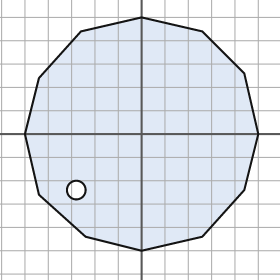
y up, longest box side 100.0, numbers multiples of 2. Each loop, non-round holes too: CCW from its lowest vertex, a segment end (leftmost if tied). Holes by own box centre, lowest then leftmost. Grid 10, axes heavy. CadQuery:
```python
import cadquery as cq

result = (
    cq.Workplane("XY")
    .moveTo(0.0, -50.0)
    .lineTo(26.0, -44.0)
    .lineTo(44.0, -24.0)
    .lineTo(50.0, 0.0)
    .lineTo(44.0, 26.0)
    .lineTo(26.0, 44.0)
    .lineTo(0.0, 50.0)
    .lineTo(-26.0, 44.0)
    .lineTo(-44.0, 24.0)
    .lineTo(-50.0, 0.0)
    .lineTo(-44.0, -26.0)
    .lineTo(-24.0, -44.0)
    .close()
    .moveTo(-28.0, -24.0)
    .circle(4.0)
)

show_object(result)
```